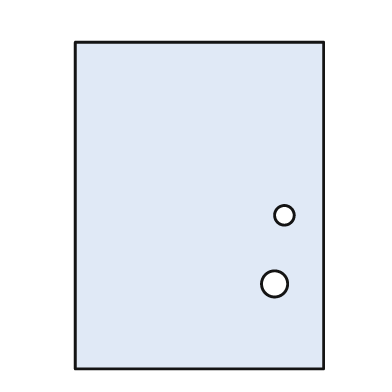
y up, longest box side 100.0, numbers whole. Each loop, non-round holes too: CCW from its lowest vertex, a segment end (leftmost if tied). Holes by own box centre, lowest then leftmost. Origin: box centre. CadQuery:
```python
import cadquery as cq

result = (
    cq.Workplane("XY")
    .moveTo(-38.0, -50.0)
    .lineTo(38.0, -50.0)
    .lineTo(38.0, 50.0)
    .lineTo(-38.0, 50.0)
    .close()
    .moveTo(23.0, -24.0)
    .circle(4.0)
    .moveTo(26.0, -3.0)
    .circle(3.0)
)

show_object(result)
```